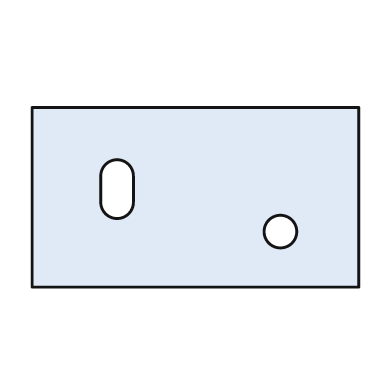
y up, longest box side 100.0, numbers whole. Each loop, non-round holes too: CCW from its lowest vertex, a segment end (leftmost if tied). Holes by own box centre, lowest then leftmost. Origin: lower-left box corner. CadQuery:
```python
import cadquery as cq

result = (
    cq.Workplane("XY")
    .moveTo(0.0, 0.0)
    .lineTo(100.0, 0.0)
    .lineTo(100.0, 55.0)
    .lineTo(0.0, 55.0)
    .close()
    .moveTo(76.0, 17.0)
    .circle(5.0)
    .moveTo(21.0, 26.0)
    .threePointArc((26.0, 21.0), (31.0, 26.0))
    .lineTo(31.0, 34.0)
    .threePointArc((26.0, 39.0), (21.0, 34.0))
    .close()
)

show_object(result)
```